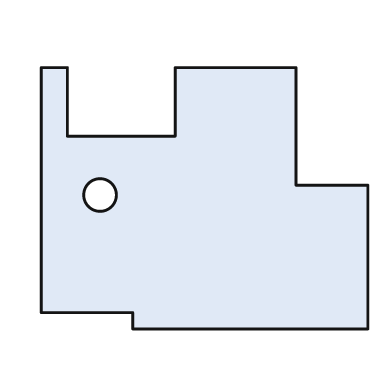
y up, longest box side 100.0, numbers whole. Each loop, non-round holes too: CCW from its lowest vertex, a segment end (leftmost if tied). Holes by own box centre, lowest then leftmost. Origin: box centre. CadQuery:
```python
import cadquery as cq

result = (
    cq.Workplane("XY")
    .moveTo(-22.0, -40.0)
    .lineTo(50.0, -40.0)
    .lineTo(50.0, 4.0)
    .lineTo(28.0, 4.0)
    .lineTo(28.0, 40.0)
    .lineTo(-9.0, 40.0)
    .lineTo(-9.0, 19.0)
    .lineTo(-42.0, 19.0)
    .lineTo(-42.0, 40.0)
    .lineTo(-50.0, 40.0)
    .lineTo(-50.0, -35.0)
    .lineTo(-22.0, -35.0)
    .close()
    .moveTo(-32.0, 1.0)
    .circle(5.0)
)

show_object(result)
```